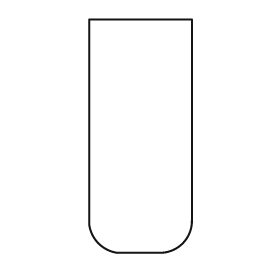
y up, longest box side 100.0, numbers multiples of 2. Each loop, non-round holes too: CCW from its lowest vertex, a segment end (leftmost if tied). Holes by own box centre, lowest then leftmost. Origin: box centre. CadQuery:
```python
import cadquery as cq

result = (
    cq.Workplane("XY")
    .moveTo(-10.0, -50.0)
    .lineTo(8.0, -50.0)
    .threePointArc((18.0, -46.0), (22.0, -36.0))
    .lineTo(22.0, 50.0)
    .lineTo(-22.0, 50.0)
    .lineTo(-22.0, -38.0)
    .threePointArc((-18.0, -46.0), (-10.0, -50.0))
    .close()
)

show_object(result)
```